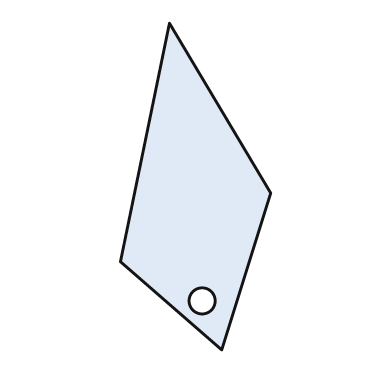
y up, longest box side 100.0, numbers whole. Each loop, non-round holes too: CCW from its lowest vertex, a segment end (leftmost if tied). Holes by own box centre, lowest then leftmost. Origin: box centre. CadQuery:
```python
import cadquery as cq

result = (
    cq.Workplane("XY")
    .moveTo(8.0, -50.0)
    .lineTo(23.0, -2.0)
    .lineTo(-8.0, 50.0)
    .lineTo(-23.0, -23.0)
    .close()
    .moveTo(2.0, -35.0)
    .circle(4.0)
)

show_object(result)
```